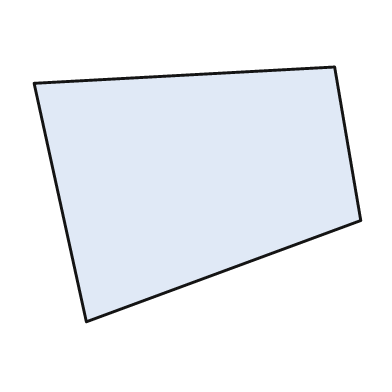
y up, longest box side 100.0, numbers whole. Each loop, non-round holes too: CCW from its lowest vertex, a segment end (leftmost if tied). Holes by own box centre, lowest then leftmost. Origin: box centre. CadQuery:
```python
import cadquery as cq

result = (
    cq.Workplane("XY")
    .moveTo(-34.0, -39.0)
    .lineTo(50.0, -8.0)
    .lineTo(42.0, 39.0)
    .lineTo(-50.0, 34.0)
    .close()
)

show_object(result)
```